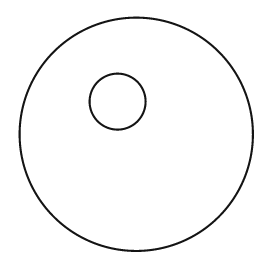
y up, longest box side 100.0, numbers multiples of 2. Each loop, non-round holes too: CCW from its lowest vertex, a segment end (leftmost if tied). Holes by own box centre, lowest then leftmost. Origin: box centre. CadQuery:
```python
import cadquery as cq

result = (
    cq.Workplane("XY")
    .moveTo(0.0, 0.0)
    .circle(50.0)
    .moveTo(-8.0, 14.0)
    .circle(12.0)
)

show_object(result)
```